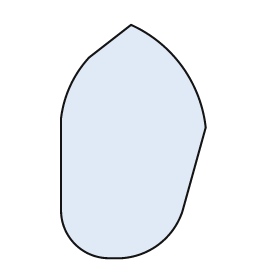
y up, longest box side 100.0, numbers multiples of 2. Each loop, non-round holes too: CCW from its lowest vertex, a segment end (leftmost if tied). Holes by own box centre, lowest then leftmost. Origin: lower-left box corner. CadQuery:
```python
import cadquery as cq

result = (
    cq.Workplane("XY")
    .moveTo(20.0, 0.0)
    .lineTo(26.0, 0.0)
    .threePointArc((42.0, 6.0), (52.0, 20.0))
    .lineTo(62.0, 56.0)
    .threePointArc((52.0, 82.0), (30.0, 100.0))
    .lineTo(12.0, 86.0)
    .threePointArc((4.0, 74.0), (0.0, 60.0))
    .lineTo(0.0, 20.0)
    .threePointArc((6.0, 6.0), (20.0, 0.0))
    .close()
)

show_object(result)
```